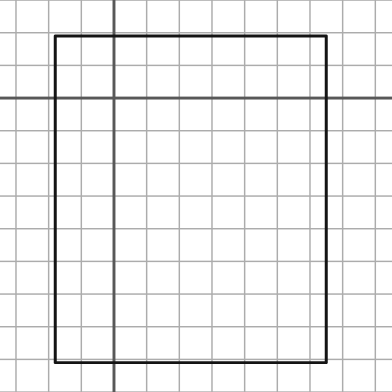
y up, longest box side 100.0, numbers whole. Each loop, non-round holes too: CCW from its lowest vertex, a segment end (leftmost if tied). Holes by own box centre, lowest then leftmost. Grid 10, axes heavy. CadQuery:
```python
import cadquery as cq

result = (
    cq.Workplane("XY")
    .moveTo(-18.0, -81.0)
    .lineTo(65.0, -81.0)
    .lineTo(65.0, 19.0)
    .lineTo(-18.0, 19.0)
    .close()
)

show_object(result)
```